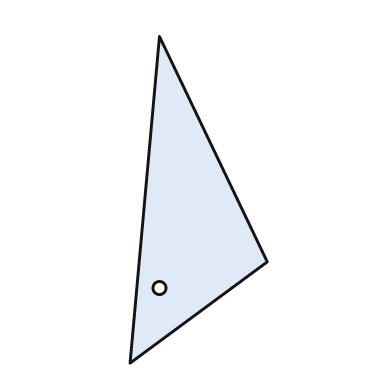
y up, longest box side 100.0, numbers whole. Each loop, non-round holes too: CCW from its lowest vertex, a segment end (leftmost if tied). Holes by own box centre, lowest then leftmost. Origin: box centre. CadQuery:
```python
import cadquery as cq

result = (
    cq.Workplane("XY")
    .moveTo(-21.0, -50.0)
    .lineTo(21.0, -19.0)
    .lineTo(-12.0, 50.0)
    .close()
    .moveTo(-12.0, -27.0)
    .circle(2.0)
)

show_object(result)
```